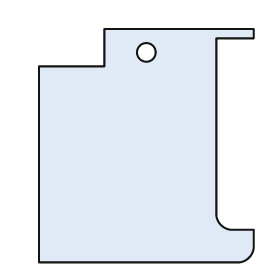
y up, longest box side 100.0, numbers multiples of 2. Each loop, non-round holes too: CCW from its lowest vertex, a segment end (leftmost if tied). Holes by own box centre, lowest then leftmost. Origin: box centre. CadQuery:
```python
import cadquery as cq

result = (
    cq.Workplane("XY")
    .moveTo(-46.0, -50.0)
    .lineTo(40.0, -50.0)
    .threePointArc((44.0, -48.0), (46.0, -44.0))
    .lineTo(46.0, -36.0)
    .lineTo(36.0, -36.0)
    .threePointArc((32.0, -34.0), (30.0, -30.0))
    .lineTo(30.0, 46.0)
    .lineTo(46.0, 46.0)
    .lineTo(46.0, 50.0)
    .lineTo(-18.0, 50.0)
    .lineTo(-18.0, 34.0)
    .lineTo(-46.0, 34.0)
    .close()
    .moveTo(0.0, 40.0)
    .circle(4.0)
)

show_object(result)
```